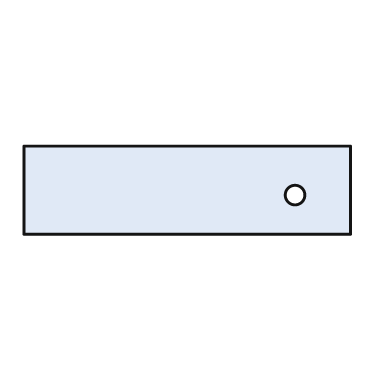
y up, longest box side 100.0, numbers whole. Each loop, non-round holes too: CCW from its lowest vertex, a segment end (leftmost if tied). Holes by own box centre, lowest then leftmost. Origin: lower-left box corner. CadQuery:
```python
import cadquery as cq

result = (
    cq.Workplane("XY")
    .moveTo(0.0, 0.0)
    .lineTo(100.0, 0.0)
    .lineTo(100.0, 27.0)
    .lineTo(0.0, 27.0)
    .close()
    .moveTo(83.0, 12.0)
    .circle(3.0)
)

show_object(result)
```